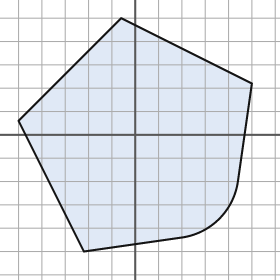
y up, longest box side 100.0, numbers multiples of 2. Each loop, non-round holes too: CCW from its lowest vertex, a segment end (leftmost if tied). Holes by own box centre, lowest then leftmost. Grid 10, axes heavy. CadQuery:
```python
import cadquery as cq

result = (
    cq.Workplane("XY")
    .moveTo(-22.0, -50.0)
    .lineTo(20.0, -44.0)
    .threePointArc((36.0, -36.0), (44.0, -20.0))
    .lineTo(50.0, 22.0)
    .lineTo(-6.0, 50.0)
    .lineTo(-50.0, 6.0)
    .close()
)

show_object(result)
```